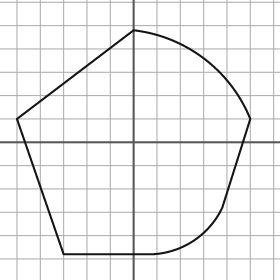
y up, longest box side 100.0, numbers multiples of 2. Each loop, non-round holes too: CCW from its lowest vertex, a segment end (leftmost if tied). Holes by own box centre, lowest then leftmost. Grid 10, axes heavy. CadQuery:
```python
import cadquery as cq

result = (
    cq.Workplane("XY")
    .moveTo(-30.0, -48.0)
    .lineTo(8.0, -48.0)
    .threePointArc((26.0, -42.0), (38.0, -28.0))
    .lineTo(50.0, 10.0)
    .threePointArc((30.0, 36.0), (0.0, 48.0))
    .lineTo(-50.0, 10.0)
    .close()
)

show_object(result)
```